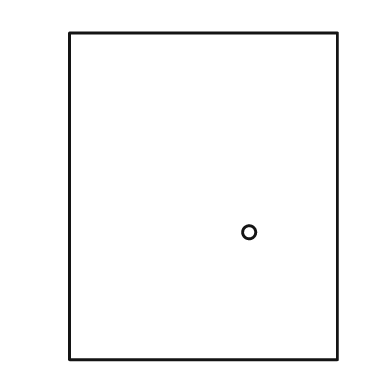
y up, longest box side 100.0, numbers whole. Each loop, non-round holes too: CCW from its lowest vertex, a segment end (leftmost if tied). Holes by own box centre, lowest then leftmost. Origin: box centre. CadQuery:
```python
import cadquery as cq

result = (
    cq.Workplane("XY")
    .moveTo(-41.0, -50.0)
    .lineTo(41.0, -50.0)
    .lineTo(41.0, 50.0)
    .lineTo(-41.0, 50.0)
    .close()
    .moveTo(14.0, -11.0)
    .circle(2.0)
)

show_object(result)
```